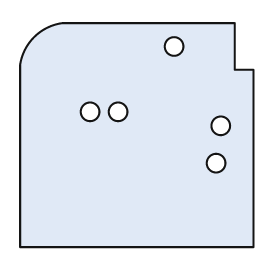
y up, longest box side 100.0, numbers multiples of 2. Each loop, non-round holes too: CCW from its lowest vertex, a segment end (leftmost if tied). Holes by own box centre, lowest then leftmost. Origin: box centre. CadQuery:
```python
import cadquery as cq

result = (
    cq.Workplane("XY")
    .moveTo(-50.0, -48.0)
    .lineTo(50.0, -48.0)
    .lineTo(50.0, 28.0)
    .lineTo(42.0, 28.0)
    .lineTo(42.0, 48.0)
    .lineTo(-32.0, 48.0)
    .threePointArc((-44.0, 42.0), (-50.0, 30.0))
    .close()
    .moveTo(34.0, -12.0)
    .circle(4.0)
    .moveTo(36.0, 4.0)
    .circle(4.0)
    .moveTo(-20.0, 10.0)
    .circle(4.0)
    .moveTo(-8.0, 10.0)
    .circle(4.0)
    .moveTo(16.0, 38.0)
    .circle(4.0)
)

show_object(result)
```